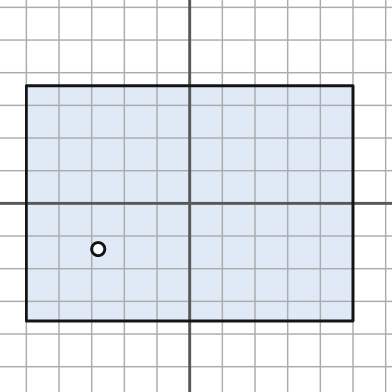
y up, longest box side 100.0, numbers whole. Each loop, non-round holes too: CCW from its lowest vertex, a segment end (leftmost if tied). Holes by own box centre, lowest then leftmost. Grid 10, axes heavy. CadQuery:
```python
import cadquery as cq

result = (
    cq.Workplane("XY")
    .moveTo(-50.0, -36.0)
    .lineTo(50.0, -36.0)
    .lineTo(50.0, 36.0)
    .lineTo(-50.0, 36.0)
    .close()
    .moveTo(-28.0, -14.0)
    .circle(2.0)
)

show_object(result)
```